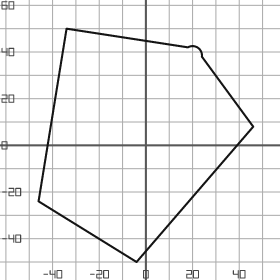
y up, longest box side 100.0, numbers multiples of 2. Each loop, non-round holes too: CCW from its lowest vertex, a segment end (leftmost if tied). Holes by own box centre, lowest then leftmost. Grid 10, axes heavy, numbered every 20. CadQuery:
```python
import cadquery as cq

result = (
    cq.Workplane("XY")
    .moveTo(-4.0, -50.0)
    .lineTo(46.0, 8.0)
    .lineTo(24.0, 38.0)
    .threePointArc((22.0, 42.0), (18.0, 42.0))
    .lineTo(-34.0, 50.0)
    .lineTo(-46.0, -24.0)
    .close()
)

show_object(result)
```